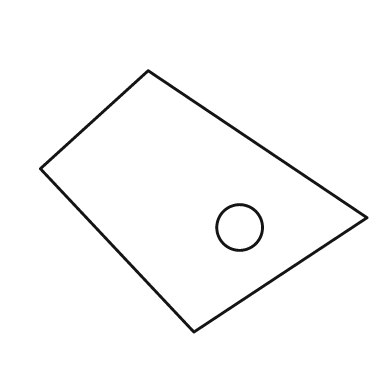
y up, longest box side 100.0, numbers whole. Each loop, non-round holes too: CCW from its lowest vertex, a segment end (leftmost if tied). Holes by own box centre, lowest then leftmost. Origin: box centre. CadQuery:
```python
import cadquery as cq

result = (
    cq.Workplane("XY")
    .moveTo(-3.0, -40.0)
    .lineTo(50.0, -5.0)
    .lineTo(-17.0, 40.0)
    .lineTo(-50.0, 10.0)
    .close()
    .moveTo(11.0, -8.0)
    .circle(7.0)
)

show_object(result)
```